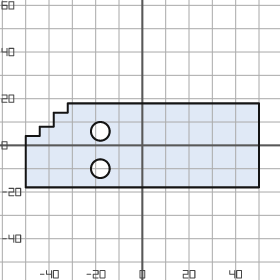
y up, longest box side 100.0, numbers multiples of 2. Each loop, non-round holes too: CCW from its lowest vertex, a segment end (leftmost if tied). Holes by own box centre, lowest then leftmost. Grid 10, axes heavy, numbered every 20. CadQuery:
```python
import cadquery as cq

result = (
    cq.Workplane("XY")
    .moveTo(-50.0, -18.0)
    .lineTo(50.0, -18.0)
    .lineTo(50.0, 18.0)
    .lineTo(-32.0, 18.0)
    .lineTo(-32.0, 14.0)
    .lineTo(-38.0, 14.0)
    .lineTo(-38.0, 8.0)
    .lineTo(-44.0, 8.0)
    .lineTo(-44.0, 4.0)
    .lineTo(-50.0, 4.0)
    .close()
    .moveTo(-18.0, -10.0)
    .circle(4.0)
    .moveTo(-18.0, 6.0)
    .circle(4.0)
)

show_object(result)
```